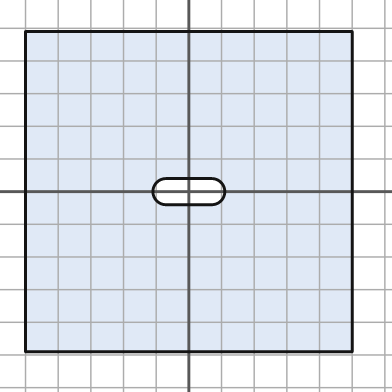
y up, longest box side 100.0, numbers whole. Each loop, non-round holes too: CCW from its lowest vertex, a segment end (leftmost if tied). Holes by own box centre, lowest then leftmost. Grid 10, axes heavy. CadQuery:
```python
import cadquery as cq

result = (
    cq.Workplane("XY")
    .moveTo(-50.0, -49.0)
    .lineTo(50.0, -49.0)
    .lineTo(50.0, 49.0)
    .lineTo(-50.0, 49.0)
    .close()
    .moveTo(-7.0, -4.0)
    .lineTo(7.0, -4.0)
    .threePointArc((11.0, 0.0), (7.0, 4.0))
    .lineTo(-7.0, 4.0)
    .threePointArc((-11.0, 0.0), (-7.0, -4.0))
    .close()
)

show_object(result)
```